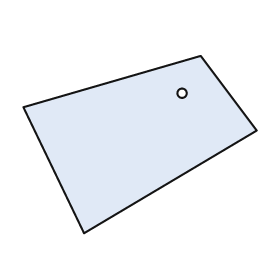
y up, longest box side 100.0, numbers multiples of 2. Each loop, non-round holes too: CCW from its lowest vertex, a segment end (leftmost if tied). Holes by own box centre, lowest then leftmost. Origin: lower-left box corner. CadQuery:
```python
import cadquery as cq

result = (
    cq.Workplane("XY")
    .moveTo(26.0, 0.0)
    .lineTo(100.0, 44.0)
    .lineTo(76.0, 76.0)
    .lineTo(0.0, 54.0)
    .close()
    .moveTo(68.0, 60.0)
    .circle(2.0)
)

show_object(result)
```